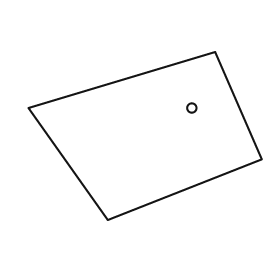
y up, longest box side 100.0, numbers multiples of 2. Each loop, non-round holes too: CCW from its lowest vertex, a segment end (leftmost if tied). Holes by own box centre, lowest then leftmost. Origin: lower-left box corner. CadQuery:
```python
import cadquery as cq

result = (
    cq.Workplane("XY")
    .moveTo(34.0, 0.0)
    .lineTo(100.0, 26.0)
    .lineTo(80.0, 72.0)
    .lineTo(0.0, 48.0)
    .close()
    .moveTo(70.0, 48.0)
    .circle(2.0)
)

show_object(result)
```